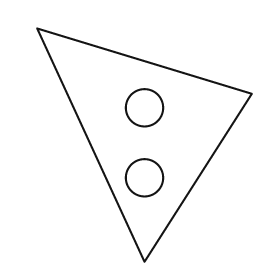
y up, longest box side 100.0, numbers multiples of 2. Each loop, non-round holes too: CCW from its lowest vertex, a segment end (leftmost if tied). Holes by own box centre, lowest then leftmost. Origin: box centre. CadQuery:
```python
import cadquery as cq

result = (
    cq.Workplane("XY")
    .moveTo(0.0, -50.0)
    .lineTo(46.0, 22.0)
    .lineTo(-46.0, 50.0)
    .close()
    .moveTo(0.0, -14.0)
    .circle(8.0)
    .moveTo(0.0, 16.0)
    .circle(8.0)
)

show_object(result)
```